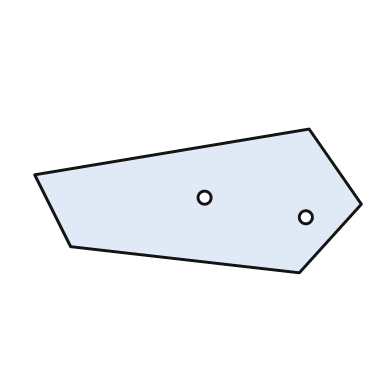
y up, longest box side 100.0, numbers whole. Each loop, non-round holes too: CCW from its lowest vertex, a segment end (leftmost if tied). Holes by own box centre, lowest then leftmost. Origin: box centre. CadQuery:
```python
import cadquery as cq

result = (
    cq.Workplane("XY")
    .moveTo(31.0, -22.0)
    .lineTo(50.0, -1.0)
    .lineTo(34.0, 22.0)
    .lineTo(-50.0, 8.0)
    .lineTo(-39.0, -14.0)
    .close()
    .moveTo(33.0, -5.0)
    .circle(2.0)
    .moveTo(2.0, 1.0)
    .circle(2.0)
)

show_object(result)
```